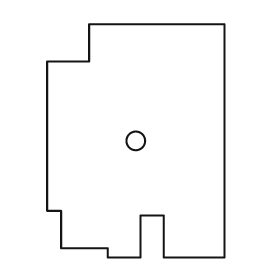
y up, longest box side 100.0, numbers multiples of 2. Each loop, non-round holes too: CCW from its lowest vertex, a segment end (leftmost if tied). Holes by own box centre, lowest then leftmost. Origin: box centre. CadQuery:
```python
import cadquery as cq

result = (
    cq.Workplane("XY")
    .moveTo(-12.0, -50.0)
    .lineTo(2.0, -50.0)
    .lineTo(2.0, -32.0)
    .lineTo(12.0, -32.0)
    .lineTo(12.0, -50.0)
    .lineTo(38.0, -50.0)
    .lineTo(38.0, 50.0)
    .lineTo(-20.0, 50.0)
    .lineTo(-20.0, 34.0)
    .lineTo(-38.0, 34.0)
    .lineTo(-38.0, -30.0)
    .lineTo(-32.0, -30.0)
    .lineTo(-32.0, -46.0)
    .lineTo(-12.0, -46.0)
    .close()
    .moveTo(0.0, 0.0)
    .circle(4.0)
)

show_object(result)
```